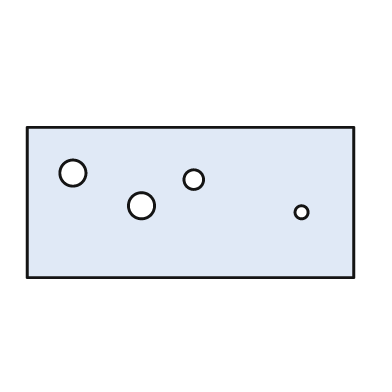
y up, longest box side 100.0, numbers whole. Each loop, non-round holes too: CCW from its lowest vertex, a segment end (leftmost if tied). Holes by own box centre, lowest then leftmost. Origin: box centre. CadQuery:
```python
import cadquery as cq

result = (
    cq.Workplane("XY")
    .moveTo(-50.0, -23.0)
    .lineTo(50.0, -23.0)
    .lineTo(50.0, 23.0)
    .lineTo(-50.0, 23.0)
    .close()
    .moveTo(34.0, -3.0)
    .circle(2.0)
    .moveTo(-15.0, -1.0)
    .circle(4.0)
    .moveTo(1.0, 7.0)
    .circle(3.0)
    .moveTo(-36.0, 9.0)
    .circle(4.0)
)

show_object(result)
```